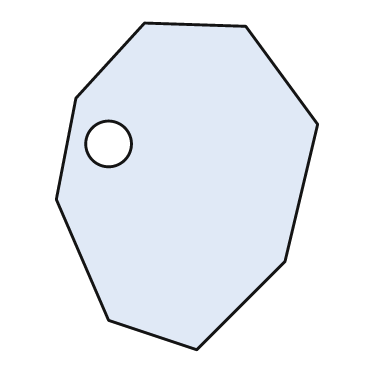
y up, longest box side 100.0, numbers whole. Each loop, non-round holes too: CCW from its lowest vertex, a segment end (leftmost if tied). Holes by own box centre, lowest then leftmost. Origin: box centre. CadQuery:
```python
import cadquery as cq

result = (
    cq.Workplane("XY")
    .moveTo(3.0, -50.0)
    .lineTo(30.0, -23.0)
    .lineTo(40.0, 19.0)
    .lineTo(18.0, 49.0)
    .lineTo(-13.0, 50.0)
    .lineTo(-34.0, 27.0)
    .lineTo(-40.0, -4.0)
    .lineTo(-24.0, -41.0)
    .close()
    .moveTo(-24.0, 13.0)
    .circle(7.0)
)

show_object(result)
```